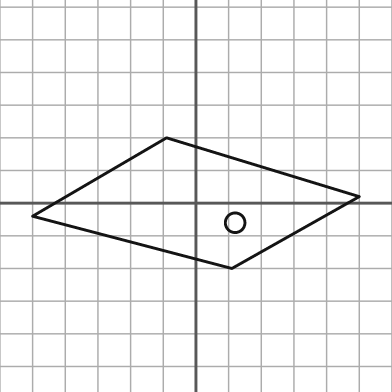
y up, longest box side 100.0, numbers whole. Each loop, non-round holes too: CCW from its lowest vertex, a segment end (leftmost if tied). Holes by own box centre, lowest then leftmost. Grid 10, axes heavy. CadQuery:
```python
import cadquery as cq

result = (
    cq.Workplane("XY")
    .moveTo(11.0, -20.0)
    .lineTo(50.0, 2.0)
    .lineTo(-9.0, 20.0)
    .lineTo(-50.0, -4.0)
    .close()
    .moveTo(12.0, -6.0)
    .circle(3.0)
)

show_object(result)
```